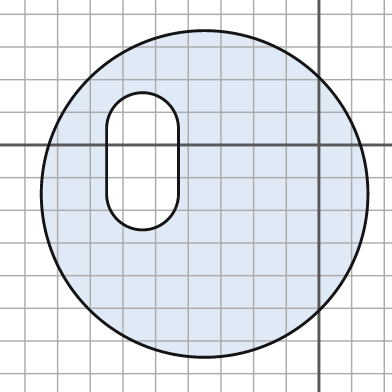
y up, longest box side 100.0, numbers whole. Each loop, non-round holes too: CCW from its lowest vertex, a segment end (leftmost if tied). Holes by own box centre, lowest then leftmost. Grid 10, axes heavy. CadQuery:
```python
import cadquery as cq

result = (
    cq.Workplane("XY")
    .moveTo(-35.0, -15.0)
    .circle(50.0)
    .moveTo(-65.0, -15.0)
    .threePointArc((-54.0, -26.0), (-43.0, -15.0))
    .lineTo(-43.0, 5.0)
    .threePointArc((-54.0, 16.0), (-65.0, 5.0))
    .close()
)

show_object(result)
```